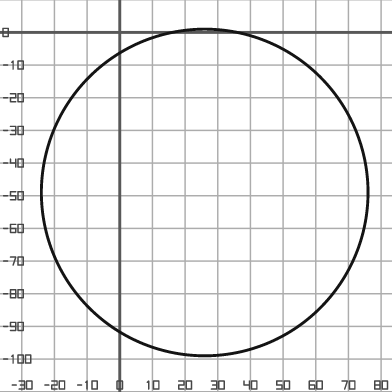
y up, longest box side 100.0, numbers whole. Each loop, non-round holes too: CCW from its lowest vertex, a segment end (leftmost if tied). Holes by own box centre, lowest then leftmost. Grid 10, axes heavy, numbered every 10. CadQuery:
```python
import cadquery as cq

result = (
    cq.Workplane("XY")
    .moveTo(26.0, -49.0)
    .circle(50.0)
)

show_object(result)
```